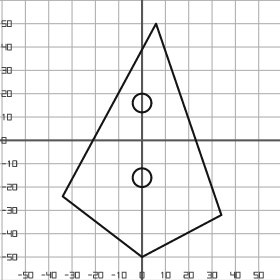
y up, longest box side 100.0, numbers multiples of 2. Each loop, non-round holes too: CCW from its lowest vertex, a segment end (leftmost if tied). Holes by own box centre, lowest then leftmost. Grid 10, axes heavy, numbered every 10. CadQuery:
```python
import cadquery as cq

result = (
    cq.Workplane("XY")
    .moveTo(0.0, -50.0)
    .lineTo(34.0, -32.0)
    .lineTo(6.0, 50.0)
    .lineTo(-34.0, -24.0)
    .close()
    .moveTo(0.0, -16.0)
    .circle(4.0)
    .moveTo(0.0, 16.0)
    .circle(4.0)
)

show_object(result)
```